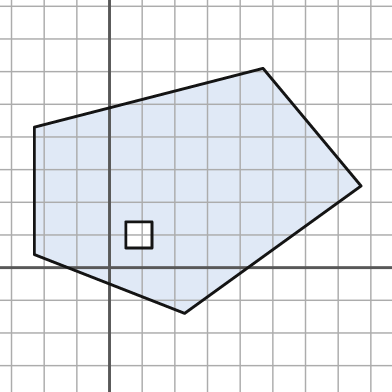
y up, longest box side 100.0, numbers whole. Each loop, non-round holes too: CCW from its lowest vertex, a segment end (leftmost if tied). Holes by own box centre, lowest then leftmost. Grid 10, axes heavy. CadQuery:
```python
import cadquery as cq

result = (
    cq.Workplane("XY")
    .moveTo(23.0, -14.0)
    .lineTo(77.0, 25.0)
    .lineTo(47.0, 61.0)
    .lineTo(-23.0, 43.0)
    .lineTo(-23.0, 4.0)
    .close()
    .moveTo(5.0, 6.0)
    .lineTo(13.0, 6.0)
    .lineTo(13.0, 14.0)
    .lineTo(5.0, 14.0)
    .close()
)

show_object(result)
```